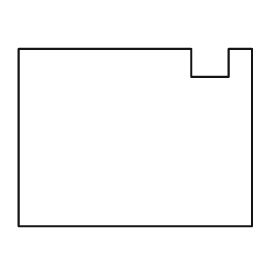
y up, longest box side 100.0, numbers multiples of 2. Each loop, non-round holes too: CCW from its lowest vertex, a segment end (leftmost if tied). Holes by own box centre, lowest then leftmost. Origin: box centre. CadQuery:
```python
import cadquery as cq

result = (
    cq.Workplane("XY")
    .moveTo(-50.0, -38.0)
    .lineTo(50.0, -38.0)
    .lineTo(50.0, 38.0)
    .lineTo(40.0, 38.0)
    .lineTo(40.0, 26.0)
    .lineTo(24.0, 26.0)
    .lineTo(24.0, 38.0)
    .lineTo(-50.0, 38.0)
    .close()
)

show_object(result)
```